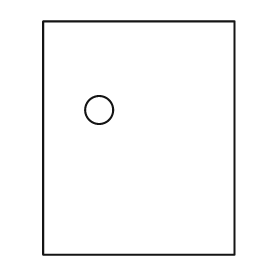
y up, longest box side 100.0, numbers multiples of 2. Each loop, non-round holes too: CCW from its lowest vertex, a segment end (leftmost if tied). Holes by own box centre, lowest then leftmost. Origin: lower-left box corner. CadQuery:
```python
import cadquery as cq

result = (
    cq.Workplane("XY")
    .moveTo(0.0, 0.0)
    .lineTo(82.0, 0.0)
    .lineTo(82.0, 100.0)
    .lineTo(0.0, 100.0)
    .close()
    .moveTo(24.0, 62.0)
    .circle(6.0)
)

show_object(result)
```